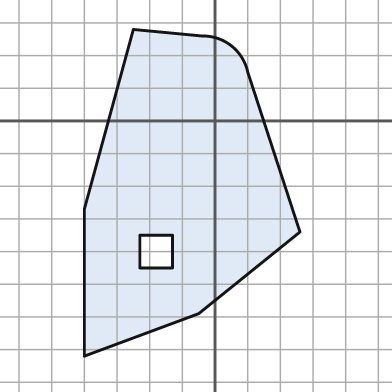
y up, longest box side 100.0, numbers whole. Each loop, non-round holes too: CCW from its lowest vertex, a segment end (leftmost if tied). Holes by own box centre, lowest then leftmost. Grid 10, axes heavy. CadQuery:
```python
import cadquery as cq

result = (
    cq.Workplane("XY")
    .moveTo(-40.0, -72.0)
    .lineTo(-5.0, -59.0)
    .lineTo(26.0, -34.0)
    .lineTo(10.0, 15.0)
    .threePointArc((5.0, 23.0), (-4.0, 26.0))
    .lineTo(-25.0, 28.0)
    .lineTo(-40.0, -27.0)
    .close()
    .moveTo(-23.0, -45.0)
    .lineTo(-13.0, -45.0)
    .lineTo(-13.0, -35.0)
    .lineTo(-23.0, -35.0)
    .close()
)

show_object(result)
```